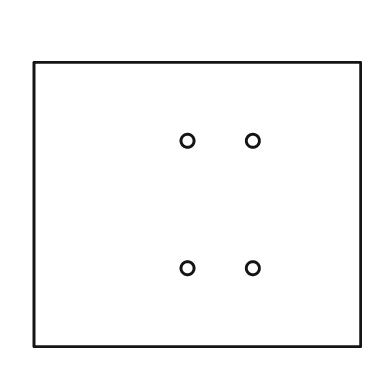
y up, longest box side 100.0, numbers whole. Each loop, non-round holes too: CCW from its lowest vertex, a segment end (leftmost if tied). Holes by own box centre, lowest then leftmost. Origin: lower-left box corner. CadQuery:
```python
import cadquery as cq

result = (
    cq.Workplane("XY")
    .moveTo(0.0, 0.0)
    .lineTo(100.0, 0.0)
    .lineTo(100.0, 87.0)
    .lineTo(0.0, 87.0)
    .close()
    .moveTo(47.0, 24.0)
    .circle(2.0)
    .moveTo(67.0, 24.0)
    .circle(2.0)
    .moveTo(47.0, 63.0)
    .circle(2.0)
    .moveTo(67.0, 63.0)
    .circle(2.0)
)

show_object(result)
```